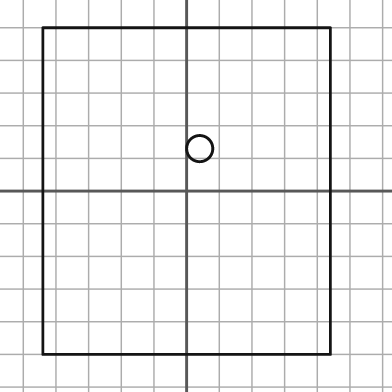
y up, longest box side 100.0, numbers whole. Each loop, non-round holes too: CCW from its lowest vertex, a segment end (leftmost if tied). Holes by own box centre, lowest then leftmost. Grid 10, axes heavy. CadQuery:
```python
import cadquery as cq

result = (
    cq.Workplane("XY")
    .moveTo(-44.0, -50.0)
    .lineTo(44.0, -50.0)
    .lineTo(44.0, 50.0)
    .lineTo(-44.0, 50.0)
    .close()
    .moveTo(4.0, 13.0)
    .circle(4.0)
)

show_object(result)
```